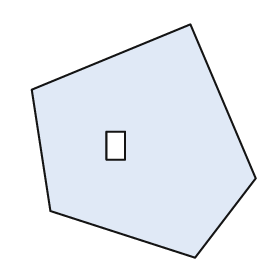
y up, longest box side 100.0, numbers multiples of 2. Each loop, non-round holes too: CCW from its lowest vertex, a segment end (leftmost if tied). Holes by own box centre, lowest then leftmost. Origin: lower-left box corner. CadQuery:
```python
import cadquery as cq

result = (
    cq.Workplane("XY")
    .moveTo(70.0, 0.0)
    .lineTo(96.0, 34.0)
    .lineTo(68.0, 100.0)
    .lineTo(0.0, 72.0)
    .lineTo(8.0, 20.0)
    .close()
    .moveTo(32.0, 42.0)
    .lineTo(40.0, 42.0)
    .lineTo(40.0, 54.0)
    .lineTo(32.0, 54.0)
    .close()
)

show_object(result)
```